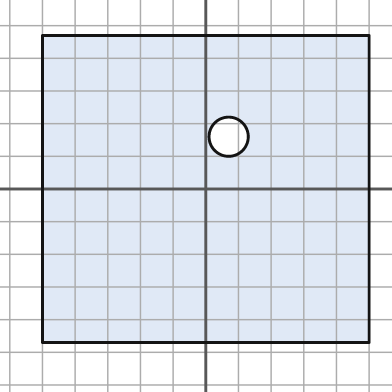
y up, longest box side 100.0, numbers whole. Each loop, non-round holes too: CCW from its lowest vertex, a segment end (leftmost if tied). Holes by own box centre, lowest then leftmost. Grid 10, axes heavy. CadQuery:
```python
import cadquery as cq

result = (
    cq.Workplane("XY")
    .moveTo(-50.0, -47.0)
    .lineTo(50.0, -47.0)
    .lineTo(50.0, 47.0)
    .lineTo(-50.0, 47.0)
    .close()
    .moveTo(7.0, 16.0)
    .circle(6.0)
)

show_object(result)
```